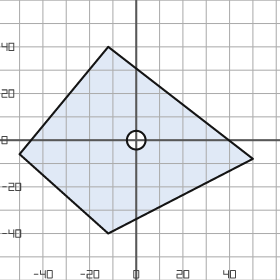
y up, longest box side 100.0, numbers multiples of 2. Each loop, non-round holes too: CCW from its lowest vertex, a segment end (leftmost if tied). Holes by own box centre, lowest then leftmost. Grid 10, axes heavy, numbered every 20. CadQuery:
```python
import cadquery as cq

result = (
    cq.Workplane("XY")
    .moveTo(-12.0, -40.0)
    .lineTo(50.0, -8.0)
    .lineTo(-12.0, 40.0)
    .lineTo(-50.0, -6.0)
    .close()
    .moveTo(0.0, 0.0)
    .circle(4.0)
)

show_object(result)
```